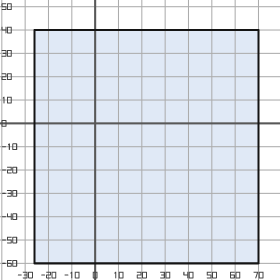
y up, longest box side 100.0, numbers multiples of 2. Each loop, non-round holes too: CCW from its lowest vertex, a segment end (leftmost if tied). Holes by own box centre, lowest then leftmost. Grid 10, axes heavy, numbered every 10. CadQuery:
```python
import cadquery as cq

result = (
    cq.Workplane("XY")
    .moveTo(-26.0, -60.0)
    .lineTo(70.0, -60.0)
    .lineTo(70.0, 40.0)
    .lineTo(-26.0, 40.0)
    .close()
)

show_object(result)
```